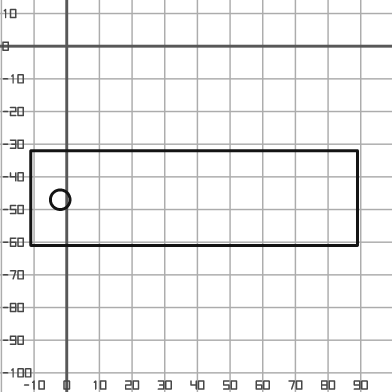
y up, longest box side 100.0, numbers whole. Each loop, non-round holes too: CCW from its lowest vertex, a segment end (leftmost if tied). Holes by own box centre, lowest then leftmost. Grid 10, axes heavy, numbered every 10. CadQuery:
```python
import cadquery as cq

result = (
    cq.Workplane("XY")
    .moveTo(-11.0, -61.0)
    .lineTo(89.0, -61.0)
    .lineTo(89.0, -32.0)
    .lineTo(-11.0, -32.0)
    .close()
    .moveTo(-2.0, -47.0)
    .circle(3.0)
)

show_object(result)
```